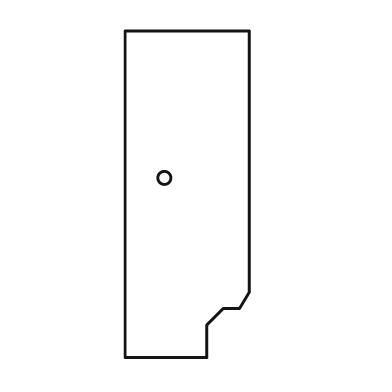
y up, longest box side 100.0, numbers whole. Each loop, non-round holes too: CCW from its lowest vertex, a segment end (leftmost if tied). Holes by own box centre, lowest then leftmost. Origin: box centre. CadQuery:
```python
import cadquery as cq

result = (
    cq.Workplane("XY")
    .moveTo(-19.0, -50.0)
    .lineTo(6.0, -50.0)
    .lineTo(6.0, -40.0)
    .lineTo(11.0, -35.0)
    .lineTo(16.0, -35.0)
    .lineTo(19.0, -30.0)
    .lineTo(19.0, 50.0)
    .lineTo(-19.0, 50.0)
    .close()
    .moveTo(-7.0, 5.0)
    .circle(2.0)
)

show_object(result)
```